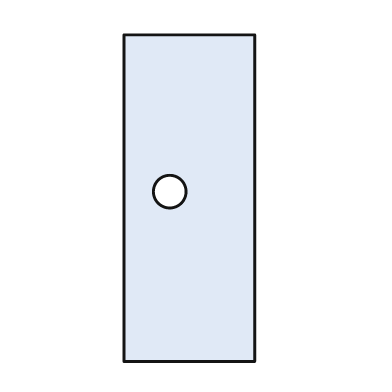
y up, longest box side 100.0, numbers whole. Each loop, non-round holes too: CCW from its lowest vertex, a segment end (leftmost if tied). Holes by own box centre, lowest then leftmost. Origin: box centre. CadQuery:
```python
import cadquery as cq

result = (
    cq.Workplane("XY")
    .moveTo(-20.0, -50.0)
    .lineTo(20.0, -50.0)
    .lineTo(20.0, 50.0)
    .lineTo(-20.0, 50.0)
    .close()
    .moveTo(-6.0, 2.0)
    .circle(5.0)
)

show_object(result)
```